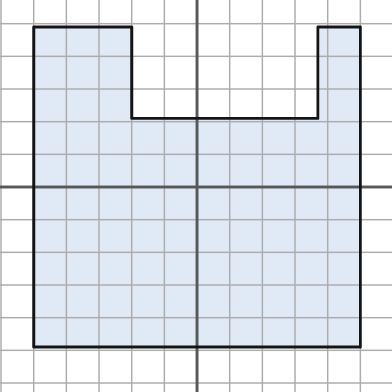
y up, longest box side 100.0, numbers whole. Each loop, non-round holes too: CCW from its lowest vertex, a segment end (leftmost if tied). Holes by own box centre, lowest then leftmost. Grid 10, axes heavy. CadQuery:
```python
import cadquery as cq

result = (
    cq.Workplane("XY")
    .moveTo(-50.0, -49.0)
    .lineTo(50.0, -49.0)
    .lineTo(50.0, 49.0)
    .lineTo(37.0, 49.0)
    .lineTo(37.0, 21.0)
    .lineTo(-20.0, 21.0)
    .lineTo(-20.0, 49.0)
    .lineTo(-50.0, 49.0)
    .close()
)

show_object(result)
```